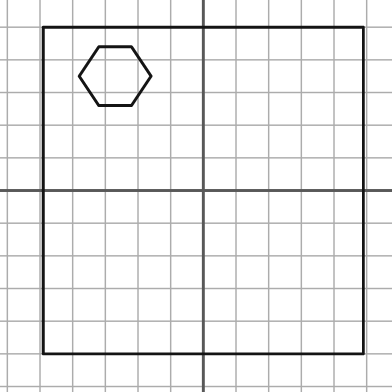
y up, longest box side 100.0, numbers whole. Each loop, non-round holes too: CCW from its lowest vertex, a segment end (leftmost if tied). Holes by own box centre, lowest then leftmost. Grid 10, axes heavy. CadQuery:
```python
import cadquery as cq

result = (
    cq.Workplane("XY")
    .moveTo(-49.0, -50.0)
    .lineTo(49.0, -50.0)
    .lineTo(49.0, 50.0)
    .lineTo(-49.0, 50.0)
    .close()
    .moveTo(-32.0, 26.0)
    .lineTo(-22.0, 26.0)
    .lineTo(-16.0, 35.0)
    .lineTo(-22.0, 44.0)
    .lineTo(-32.0, 44.0)
    .lineTo(-38.0, 35.0)
    .close()
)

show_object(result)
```